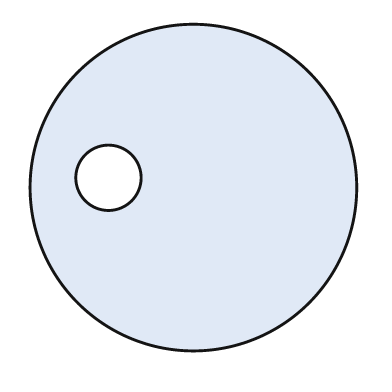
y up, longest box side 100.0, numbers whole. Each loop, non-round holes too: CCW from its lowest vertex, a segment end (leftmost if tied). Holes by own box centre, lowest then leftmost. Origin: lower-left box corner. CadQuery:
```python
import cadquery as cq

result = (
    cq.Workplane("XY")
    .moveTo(50.0, 50.0)
    .circle(50.0)
    .moveTo(24.0, 53.0)
    .circle(10.0)
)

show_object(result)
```